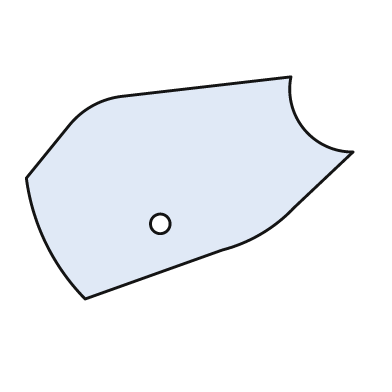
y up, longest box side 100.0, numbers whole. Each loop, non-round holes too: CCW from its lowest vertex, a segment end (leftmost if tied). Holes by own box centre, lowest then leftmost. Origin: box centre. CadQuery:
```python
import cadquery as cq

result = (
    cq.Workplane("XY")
    .moveTo(-32.0, -34.0)
    .lineTo(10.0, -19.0)
    .threePointArc((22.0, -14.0), (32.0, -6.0))
    .lineTo(50.0, 11.0)
    .threePointArc((35.0, 18.0), (31.0, 34.0))
    .lineTo(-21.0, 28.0)
    .threePointArc((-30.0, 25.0), (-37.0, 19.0))
    .lineTo(-50.0, 3.0)
    .threePointArc((-44.0, -17.0), (-32.0, -34.0))
    .close()
    .moveTo(-9.0, -11.0)
    .circle(3.0)
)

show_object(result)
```